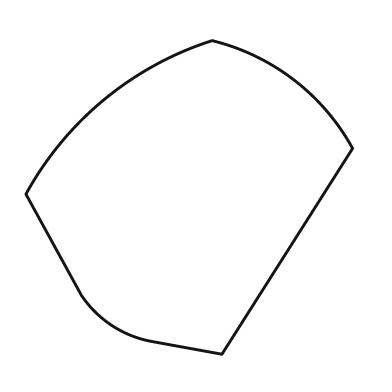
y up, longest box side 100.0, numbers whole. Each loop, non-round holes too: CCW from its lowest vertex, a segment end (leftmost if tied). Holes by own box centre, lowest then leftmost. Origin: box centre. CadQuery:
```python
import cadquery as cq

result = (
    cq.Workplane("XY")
    .moveTo(10.0, -48.0)
    .lineTo(50.0, 15.0)
    .threePointArc((32.0, 36.0), (7.0, 48.0))
    .threePointArc((-26.0, 30.0), (-50.0, 1.0))
    .lineTo(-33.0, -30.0)
    .threePointArc((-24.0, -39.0), (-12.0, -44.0))
    .close()
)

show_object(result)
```